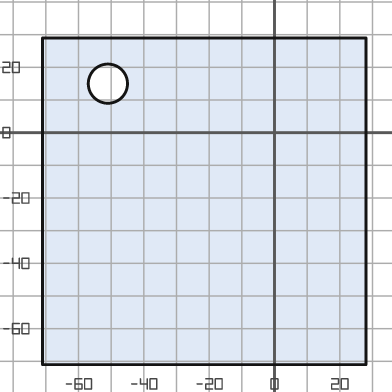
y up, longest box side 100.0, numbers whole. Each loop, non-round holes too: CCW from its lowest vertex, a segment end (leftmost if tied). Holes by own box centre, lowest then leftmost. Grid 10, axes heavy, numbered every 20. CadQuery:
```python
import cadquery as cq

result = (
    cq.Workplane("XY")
    .moveTo(-71.0, -71.0)
    .lineTo(28.0, -71.0)
    .lineTo(28.0, 29.0)
    .lineTo(-71.0, 29.0)
    .close()
    .moveTo(-51.0, 15.0)
    .circle(6.0)
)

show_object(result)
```